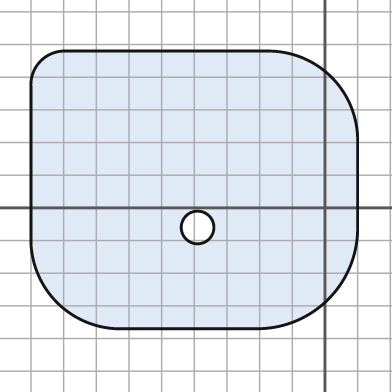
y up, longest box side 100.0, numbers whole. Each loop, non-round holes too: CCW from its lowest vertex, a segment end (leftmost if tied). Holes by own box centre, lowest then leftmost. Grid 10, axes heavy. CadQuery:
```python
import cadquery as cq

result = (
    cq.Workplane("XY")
    .moveTo(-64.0, -37.0)
    .lineTo(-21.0, -37.0)
    .threePointArc((1.0, -28.0), (10.0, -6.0))
    .lineTo(10.0, 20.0)
    .threePointArc((2.0, 40.0), (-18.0, 48.0))
    .lineTo(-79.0, 48.0)
    .threePointArc((-87.0, 45.0), (-90.0, 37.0))
    .lineTo(-90.0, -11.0)
    .threePointArc((-82.0, -29.0), (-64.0, -37.0))
    .close()
    .moveTo(-39.0, -6.0)
    .circle(5.0)
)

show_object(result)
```